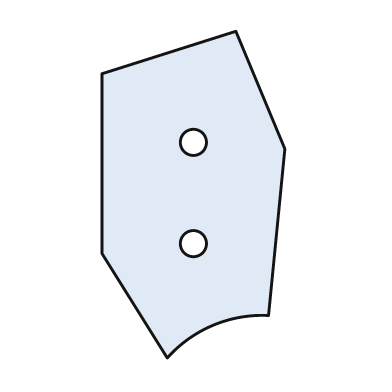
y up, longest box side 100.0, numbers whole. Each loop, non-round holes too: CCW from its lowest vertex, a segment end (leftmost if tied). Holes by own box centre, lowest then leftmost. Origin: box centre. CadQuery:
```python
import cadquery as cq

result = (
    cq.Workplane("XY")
    .moveTo(-8.0, -50.0)
    .threePointArc((6.0, -40.0), (23.0, -37.0))
    .lineTo(28.0, 14.0)
    .lineTo(13.0, 50.0)
    .lineTo(-28.0, 37.0)
    .lineTo(-28.0, -18.0)
    .close()
    .moveTo(0.0, -15.0)
    .circle(4.0)
    .moveTo(0.0, 16.0)
    .circle(4.0)
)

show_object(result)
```